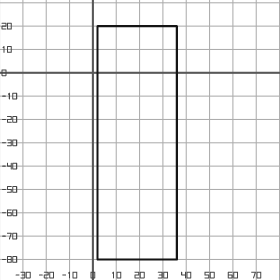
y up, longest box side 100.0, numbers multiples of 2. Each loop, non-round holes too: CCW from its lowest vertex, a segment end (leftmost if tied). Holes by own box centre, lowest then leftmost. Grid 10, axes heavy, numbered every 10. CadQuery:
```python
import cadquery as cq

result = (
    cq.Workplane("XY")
    .moveTo(2.0, -80.0)
    .lineTo(36.0, -80.0)
    .lineTo(36.0, 20.0)
    .lineTo(2.0, 20.0)
    .close()
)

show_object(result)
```